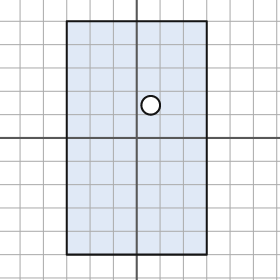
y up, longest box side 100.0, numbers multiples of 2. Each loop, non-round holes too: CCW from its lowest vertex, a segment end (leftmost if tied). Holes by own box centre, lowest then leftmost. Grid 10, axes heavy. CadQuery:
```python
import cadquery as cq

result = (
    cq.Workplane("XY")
    .moveTo(-30.0, -50.0)
    .lineTo(30.0, -50.0)
    .lineTo(30.0, 50.0)
    .lineTo(-30.0, 50.0)
    .close()
    .moveTo(6.0, 14.0)
    .circle(4.0)
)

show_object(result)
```